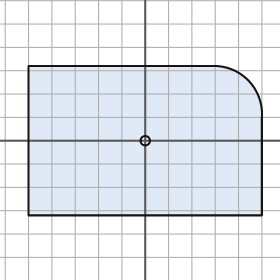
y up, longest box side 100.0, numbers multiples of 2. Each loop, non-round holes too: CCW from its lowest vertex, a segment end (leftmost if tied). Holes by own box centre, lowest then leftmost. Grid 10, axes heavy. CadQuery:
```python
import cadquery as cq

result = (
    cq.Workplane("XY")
    .moveTo(-50.0, -32.0)
    .lineTo(50.0, -32.0)
    .lineTo(50.0, 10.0)
    .threePointArc((44.0, 26.0), (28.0, 32.0))
    .lineTo(-50.0, 32.0)
    .close()
    .moveTo(0.0, 0.0)
    .circle(2.0)
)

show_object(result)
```